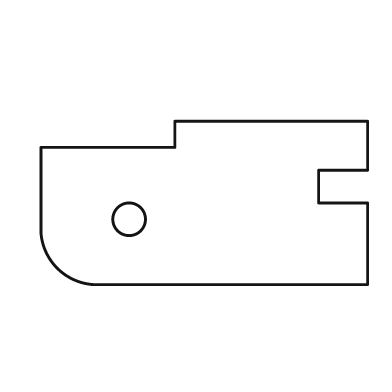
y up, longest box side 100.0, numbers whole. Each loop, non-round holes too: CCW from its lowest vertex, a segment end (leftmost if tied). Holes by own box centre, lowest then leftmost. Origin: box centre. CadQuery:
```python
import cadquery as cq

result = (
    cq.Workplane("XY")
    .moveTo(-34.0, -25.0)
    .lineTo(50.0, -25.0)
    .lineTo(50.0, 0.0)
    .lineTo(35.0, 0.0)
    .lineTo(35.0, 10.0)
    .lineTo(50.0, 10.0)
    .lineTo(50.0, 25.0)
    .lineTo(-9.0, 25.0)
    .lineTo(-9.0, 17.0)
    .lineTo(-50.0, 17.0)
    .lineTo(-50.0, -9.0)
    .threePointArc((-45.0, -20.0), (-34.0, -25.0))
    .close()
    .moveTo(-23.0, -5.0)
    .circle(5.0)
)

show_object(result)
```